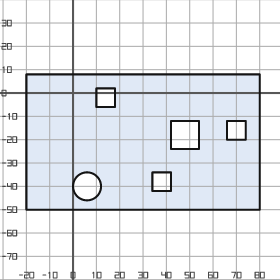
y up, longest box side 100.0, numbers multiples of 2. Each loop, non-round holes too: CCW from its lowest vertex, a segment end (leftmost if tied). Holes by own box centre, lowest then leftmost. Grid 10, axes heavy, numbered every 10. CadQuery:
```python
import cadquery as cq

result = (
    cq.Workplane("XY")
    .moveTo(-20.0, -50.0)
    .lineTo(80.0, -50.0)
    .lineTo(80.0, 8.0)
    .lineTo(-20.0, 8.0)
    .close()
    .moveTo(6.0, -40.0)
    .circle(6.0)
    .moveTo(34.0, -42.0)
    .lineTo(42.0, -42.0)
    .lineTo(42.0, -34.0)
    .lineTo(34.0, -34.0)
    .close()
    .moveTo(42.0, -24.0)
    .lineTo(54.0, -24.0)
    .lineTo(54.0, -12.0)
    .lineTo(42.0, -12.0)
    .close()
    .moveTo(66.0, -20.0)
    .lineTo(74.0, -20.0)
    .lineTo(74.0, -12.0)
    .lineTo(66.0, -12.0)
    .close()
    .moveTo(10.0, -6.0)
    .lineTo(18.0, -6.0)
    .lineTo(18.0, 2.0)
    .lineTo(10.0, 2.0)
    .close()
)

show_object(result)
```